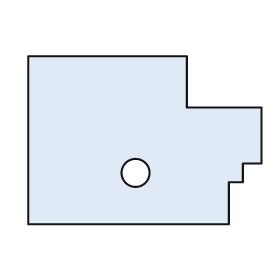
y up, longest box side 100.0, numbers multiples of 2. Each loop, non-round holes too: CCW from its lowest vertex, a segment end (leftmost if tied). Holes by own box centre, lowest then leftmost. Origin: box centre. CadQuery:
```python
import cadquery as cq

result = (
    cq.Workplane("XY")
    .moveTo(-50.0, -36.0)
    .lineTo(36.0, -36.0)
    .lineTo(36.0, -18.0)
    .lineTo(42.0, -18.0)
    .lineTo(42.0, -10.0)
    .lineTo(50.0, -10.0)
    .lineTo(50.0, 14.0)
    .lineTo(18.0, 14.0)
    .lineTo(18.0, 36.0)
    .lineTo(-50.0, 36.0)
    .close()
    .moveTo(-4.0, -14.0)
    .circle(6.0)
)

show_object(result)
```